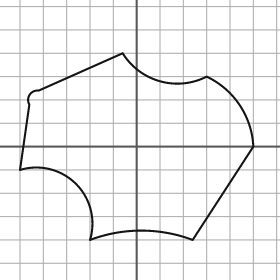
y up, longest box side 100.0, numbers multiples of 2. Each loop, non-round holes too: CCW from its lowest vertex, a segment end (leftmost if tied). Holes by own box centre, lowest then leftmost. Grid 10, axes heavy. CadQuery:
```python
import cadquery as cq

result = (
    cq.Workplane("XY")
    .moveTo(-20.0, -40.0)
    .threePointArc((2.0, -36.0), (24.0, -40.0))
    .lineTo(50.0, 0.0)
    .threePointArc((44.0, 18.0), (30.0, 30.0))
    .threePointArc((10.0, 28.0), (-6.0, 40.0))
    .lineTo(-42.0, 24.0)
    .threePointArc((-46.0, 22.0), (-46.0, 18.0))
    .lineTo(-50.0, -10.0)
    .threePointArc((-26.0, -16.0), (-20.0, -40.0))
    .close()
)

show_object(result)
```